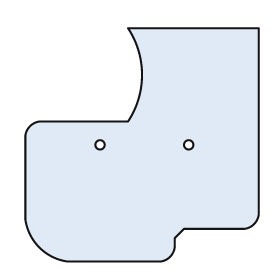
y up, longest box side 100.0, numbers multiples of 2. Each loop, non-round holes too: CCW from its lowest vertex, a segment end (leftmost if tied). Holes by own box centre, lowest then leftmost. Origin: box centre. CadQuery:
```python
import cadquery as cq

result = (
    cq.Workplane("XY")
    .moveTo(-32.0, -50.0)
    .lineTo(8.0, -50.0)
    .threePointArc((12.0, -48.0), (14.0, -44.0))
    .lineTo(14.0, -40.0)
    .lineTo(18.0, -36.0)
    .lineTo(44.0, -36.0)
    .threePointArc((48.0, -34.0), (50.0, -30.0))
    .lineTo(50.0, 50.0)
    .lineTo(-6.0, 50.0)
    .threePointArc((0.0, 30.0), (-6.0, 10.0))
    .lineTo(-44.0, 10.0)
    .threePointArc((-48.0, 8.0), (-50.0, 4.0))
    .lineTo(-50.0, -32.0)
    .threePointArc((-44.0, -44.0), (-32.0, -50.0))
    .close()
    .moveTo(-18.0, 0.0)
    .circle(2.0)
    .moveTo(20.0, 0.0)
    .circle(2.0)
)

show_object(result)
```